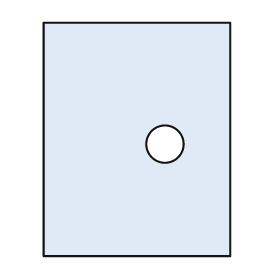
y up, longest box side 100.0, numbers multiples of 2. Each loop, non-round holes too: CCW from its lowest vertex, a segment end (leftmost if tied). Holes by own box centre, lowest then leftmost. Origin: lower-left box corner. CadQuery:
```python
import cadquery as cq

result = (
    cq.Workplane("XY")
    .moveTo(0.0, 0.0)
    .lineTo(80.0, 0.0)
    .lineTo(80.0, 100.0)
    .lineTo(0.0, 100.0)
    .close()
    .moveTo(52.0, 48.0)
    .circle(8.0)
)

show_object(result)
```